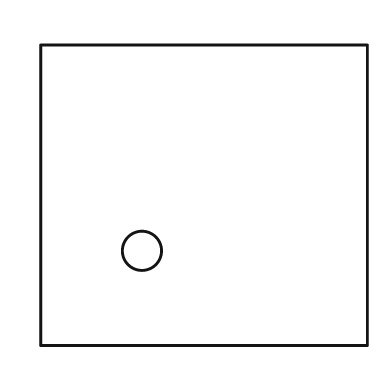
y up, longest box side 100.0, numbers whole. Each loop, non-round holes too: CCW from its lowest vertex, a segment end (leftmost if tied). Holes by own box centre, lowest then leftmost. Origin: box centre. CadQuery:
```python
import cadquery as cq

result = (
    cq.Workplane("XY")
    .moveTo(-50.0, -46.0)
    .lineTo(50.0, -46.0)
    .lineTo(50.0, 46.0)
    .lineTo(-50.0, 46.0)
    .close()
    .moveTo(-19.0, -17.0)
    .circle(6.0)
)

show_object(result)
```